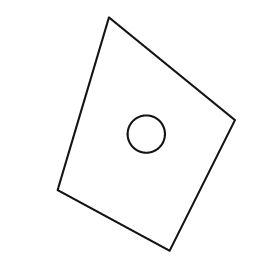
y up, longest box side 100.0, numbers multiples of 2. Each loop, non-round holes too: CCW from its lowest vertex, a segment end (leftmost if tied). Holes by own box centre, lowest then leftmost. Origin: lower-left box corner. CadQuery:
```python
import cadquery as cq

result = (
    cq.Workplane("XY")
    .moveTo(48.0, 0.0)
    .lineTo(76.0, 56.0)
    .lineTo(22.0, 100.0)
    .lineTo(0.0, 26.0)
    .close()
    .moveTo(38.0, 50.0)
    .circle(8.0)
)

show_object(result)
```